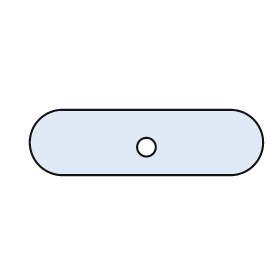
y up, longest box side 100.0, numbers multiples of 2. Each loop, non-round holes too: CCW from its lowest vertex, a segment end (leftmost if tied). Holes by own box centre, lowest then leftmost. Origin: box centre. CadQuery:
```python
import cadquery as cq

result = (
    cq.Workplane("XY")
    .moveTo(-36.0, -14.0)
    .lineTo(36.0, -14.0)
    .threePointArc((50.0, 0.0), (36.0, 14.0))
    .lineTo(-36.0, 14.0)
    .threePointArc((-50.0, 0.0), (-36.0, -14.0))
    .close()
    .moveTo(0.0, -2.0)
    .circle(4.0)
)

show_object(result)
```